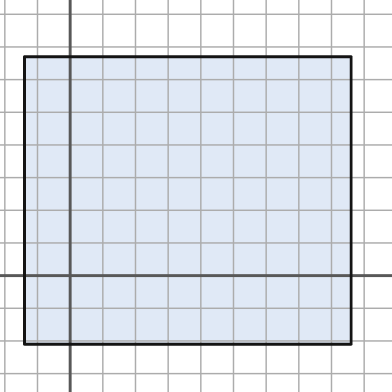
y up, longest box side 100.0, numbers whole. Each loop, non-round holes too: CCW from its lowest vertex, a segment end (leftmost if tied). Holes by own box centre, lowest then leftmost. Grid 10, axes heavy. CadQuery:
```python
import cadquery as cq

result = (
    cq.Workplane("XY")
    .moveTo(-14.0, -21.0)
    .lineTo(86.0, -21.0)
    .lineTo(86.0, 67.0)
    .lineTo(-14.0, 67.0)
    .close()
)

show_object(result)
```